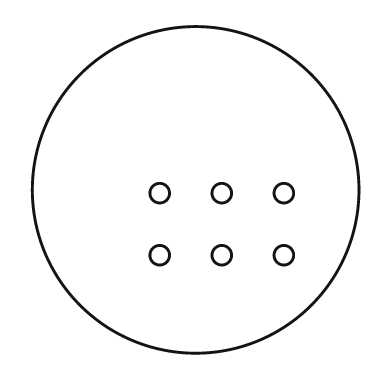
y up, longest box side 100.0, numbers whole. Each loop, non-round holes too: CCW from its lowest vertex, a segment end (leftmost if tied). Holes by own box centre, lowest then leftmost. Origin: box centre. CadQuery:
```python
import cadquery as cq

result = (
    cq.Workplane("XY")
    .moveTo(0.0, 0.0)
    .circle(50.0)
    .moveTo(-11.0, -20.0)
    .circle(3.0)
    .moveTo(8.0, -20.0)
    .circle(3.0)
    .moveTo(27.0, -20.0)
    .circle(3.0)
    .moveTo(-11.0, -1.0)
    .circle(3.0)
    .moveTo(8.0, -1.0)
    .circle(3.0)
    .moveTo(27.0, -1.0)
    .circle(3.0)
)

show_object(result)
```